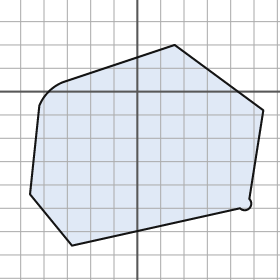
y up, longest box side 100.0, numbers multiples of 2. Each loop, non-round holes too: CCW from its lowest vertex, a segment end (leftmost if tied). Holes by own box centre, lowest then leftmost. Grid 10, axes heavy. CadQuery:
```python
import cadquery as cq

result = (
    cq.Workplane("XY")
    .moveTo(-28.0, -66.0)
    .lineTo(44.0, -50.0)
    .threePointArc((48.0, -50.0), (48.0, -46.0))
    .lineTo(54.0, -8.0)
    .lineTo(16.0, 20.0)
    .lineTo(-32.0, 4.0)
    .threePointArc((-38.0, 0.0), (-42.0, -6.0))
    .lineTo(-46.0, -44.0)
    .close()
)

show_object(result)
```